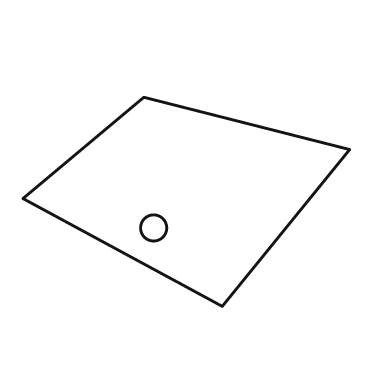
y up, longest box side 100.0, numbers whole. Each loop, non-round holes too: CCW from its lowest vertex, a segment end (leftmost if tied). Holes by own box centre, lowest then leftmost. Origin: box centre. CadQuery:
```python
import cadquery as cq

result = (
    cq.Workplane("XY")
    .moveTo(11.0, -32.0)
    .lineTo(50.0, 16.0)
    .lineTo(-13.0, 32.0)
    .lineTo(-50.0, 1.0)
    .close()
    .moveTo(-10.0, -8.0)
    .circle(4.0)
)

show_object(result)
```